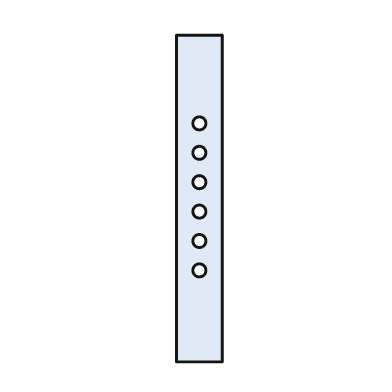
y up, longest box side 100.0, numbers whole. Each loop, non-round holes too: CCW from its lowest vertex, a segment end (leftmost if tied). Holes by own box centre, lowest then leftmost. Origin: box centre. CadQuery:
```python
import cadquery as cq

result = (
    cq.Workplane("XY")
    .moveTo(-7.0, -50.0)
    .lineTo(7.0, -50.0)
    .lineTo(7.0, 50.0)
    .lineTo(-7.0, 50.0)
    .close()
    .moveTo(0.0, -22.0)
    .circle(2.0)
    .moveTo(0.0, -13.0)
    .circle(2.0)
    .moveTo(0.0, -4.0)
    .circle(2.0)
    .moveTo(0.0, 5.0)
    .circle(2.0)
    .moveTo(0.0, 14.0)
    .circle(2.0)
    .moveTo(0.0, 23.0)
    .circle(2.0)
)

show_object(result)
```